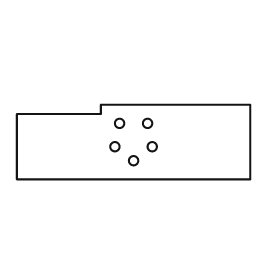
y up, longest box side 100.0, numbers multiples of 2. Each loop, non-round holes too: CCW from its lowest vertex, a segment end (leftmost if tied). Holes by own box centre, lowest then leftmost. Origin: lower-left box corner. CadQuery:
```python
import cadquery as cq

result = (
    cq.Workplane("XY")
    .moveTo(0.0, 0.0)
    .lineTo(100.0, 0.0)
    .lineTo(100.0, 32.0)
    .lineTo(36.0, 32.0)
    .lineTo(36.0, 28.0)
    .lineTo(0.0, 28.0)
    .close()
    .moveTo(50.0, 8.0)
    .circle(2.0)
    .moveTo(42.0, 14.0)
    .circle(2.0)
    .moveTo(58.0, 14.0)
    .circle(2.0)
    .moveTo(44.0, 24.0)
    .circle(2.0)
    .moveTo(56.0, 24.0)
    .circle(2.0)
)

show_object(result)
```